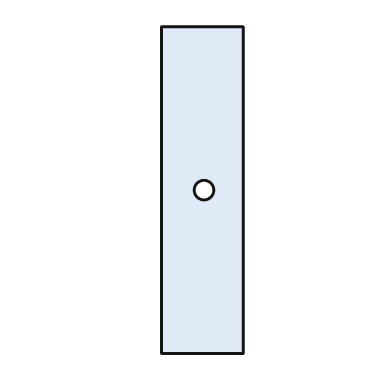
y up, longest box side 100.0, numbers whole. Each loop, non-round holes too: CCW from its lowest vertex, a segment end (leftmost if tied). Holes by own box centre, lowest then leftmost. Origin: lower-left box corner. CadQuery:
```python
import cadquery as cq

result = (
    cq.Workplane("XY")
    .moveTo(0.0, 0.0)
    .lineTo(25.0, 0.0)
    .lineTo(25.0, 100.0)
    .lineTo(0.0, 100.0)
    .close()
    .moveTo(13.0, 50.0)
    .circle(3.0)
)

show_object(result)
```